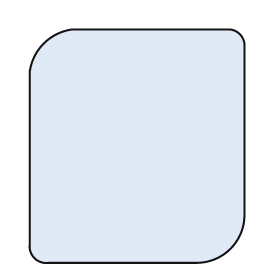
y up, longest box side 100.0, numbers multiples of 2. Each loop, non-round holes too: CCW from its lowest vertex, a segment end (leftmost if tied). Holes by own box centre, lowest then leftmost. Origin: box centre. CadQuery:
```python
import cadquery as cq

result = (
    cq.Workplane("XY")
    .moveTo(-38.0, -50.0)
    .lineTo(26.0, -50.0)
    .threePointArc((40.0, -44.0), (46.0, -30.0))
    .lineTo(46.0, 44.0)
    .threePointArc((44.0, 48.0), (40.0, 50.0))
    .lineTo(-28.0, 50.0)
    .threePointArc((-40.0, 44.0), (-46.0, 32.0))
    .lineTo(-46.0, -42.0)
    .threePointArc((-44.0, -48.0), (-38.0, -50.0))
    .close()
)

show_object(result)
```